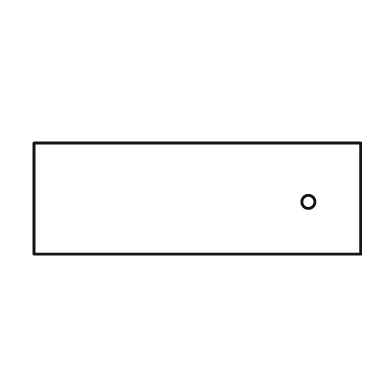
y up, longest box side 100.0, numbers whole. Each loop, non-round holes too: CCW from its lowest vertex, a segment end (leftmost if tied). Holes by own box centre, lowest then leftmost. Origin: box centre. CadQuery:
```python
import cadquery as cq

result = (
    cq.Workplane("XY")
    .moveTo(-50.0, -17.0)
    .lineTo(50.0, -17.0)
    .lineTo(50.0, 17.0)
    .lineTo(-50.0, 17.0)
    .close()
    .moveTo(34.0, -1.0)
    .circle(2.0)
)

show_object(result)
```